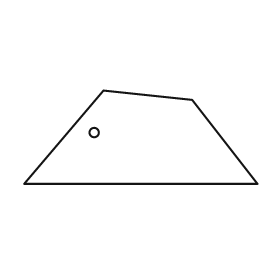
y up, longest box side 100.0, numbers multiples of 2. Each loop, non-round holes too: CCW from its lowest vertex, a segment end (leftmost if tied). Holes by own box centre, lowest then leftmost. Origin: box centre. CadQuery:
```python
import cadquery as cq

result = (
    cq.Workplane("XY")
    .moveTo(-50.0, -20.0)
    .lineTo(50.0, -20.0)
    .lineTo(22.0, 16.0)
    .lineTo(-16.0, 20.0)
    .close()
    .moveTo(-20.0, 2.0)
    .circle(2.0)
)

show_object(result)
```